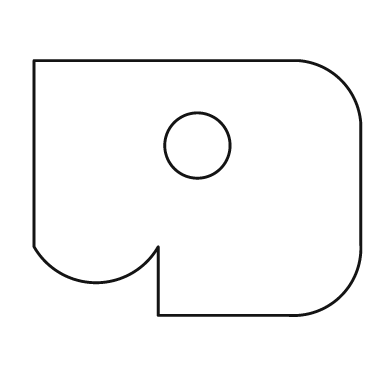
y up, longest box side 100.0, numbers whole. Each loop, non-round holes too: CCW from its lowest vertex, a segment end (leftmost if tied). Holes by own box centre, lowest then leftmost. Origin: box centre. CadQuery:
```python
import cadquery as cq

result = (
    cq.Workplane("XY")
    .moveTo(-12.0, -39.0)
    .lineTo(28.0, -39.0)
    .threePointArc((44.0, -33.0), (50.0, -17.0))
    .lineTo(50.0, 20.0)
    .threePointArc((44.0, 33.0), (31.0, 39.0))
    .lineTo(-50.0, 39.0)
    .lineTo(-50.0, -18.0)
    .threePointArc((-31.0, -29.0), (-12.0, -18.0))
    .close()
    .moveTo(0.0, 13.0)
    .circle(10.0)
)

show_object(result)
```